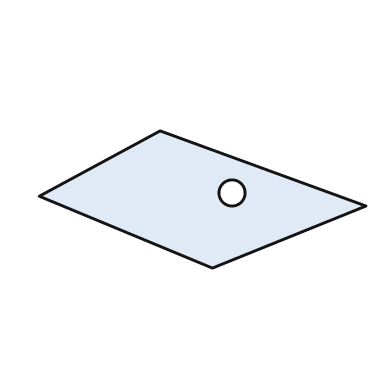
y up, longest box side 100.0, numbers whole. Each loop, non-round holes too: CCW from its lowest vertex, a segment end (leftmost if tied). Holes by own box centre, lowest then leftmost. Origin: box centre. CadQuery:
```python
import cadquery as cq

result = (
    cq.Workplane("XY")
    .moveTo(3.0, -21.0)
    .lineTo(50.0, -2.0)
    .lineTo(-13.0, 21.0)
    .lineTo(-50.0, 1.0)
    .close()
    .moveTo(9.0, 2.0)
    .circle(4.0)
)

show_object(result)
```